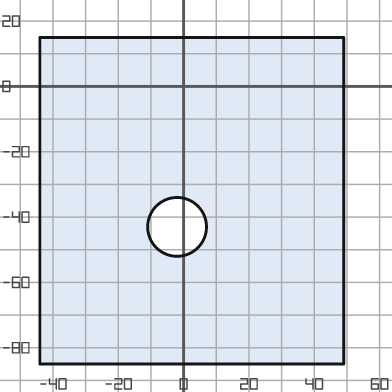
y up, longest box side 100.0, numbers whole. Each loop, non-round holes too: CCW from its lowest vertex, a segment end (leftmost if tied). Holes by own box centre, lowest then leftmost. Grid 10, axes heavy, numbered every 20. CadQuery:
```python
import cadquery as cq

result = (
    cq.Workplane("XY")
    .moveTo(-44.0, -85.0)
    .lineTo(49.0, -85.0)
    .lineTo(49.0, 15.0)
    .lineTo(-44.0, 15.0)
    .close()
    .moveTo(-2.0, -43.0)
    .circle(9.0)
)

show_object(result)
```